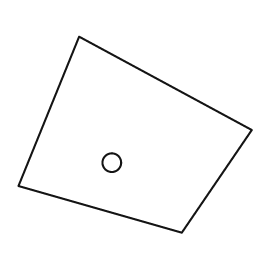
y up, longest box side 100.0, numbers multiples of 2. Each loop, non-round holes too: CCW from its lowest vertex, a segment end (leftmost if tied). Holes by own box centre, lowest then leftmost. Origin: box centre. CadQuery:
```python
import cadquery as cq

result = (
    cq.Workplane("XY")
    .moveTo(20.0, -42.0)
    .lineTo(50.0, 2.0)
    .lineTo(-24.0, 42.0)
    .lineTo(-50.0, -22.0)
    .close()
    .moveTo(-10.0, -12.0)
    .circle(4.0)
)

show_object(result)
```